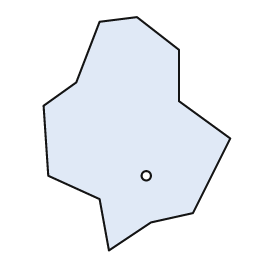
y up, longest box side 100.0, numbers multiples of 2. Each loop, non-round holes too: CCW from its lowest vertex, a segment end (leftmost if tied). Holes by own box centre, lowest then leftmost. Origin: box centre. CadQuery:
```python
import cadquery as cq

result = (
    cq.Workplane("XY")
    .moveTo(-12.0, -50.0)
    .lineTo(6.0, -38.0)
    .lineTo(24.0, -34.0)
    .lineTo(40.0, -2.0)
    .lineTo(18.0, 14.0)
    .lineTo(18.0, 36.0)
    .lineTo(0.0, 50.0)
    .lineTo(-16.0, 48.0)
    .lineTo(-26.0, 22.0)
    .lineTo(-40.0, 12.0)
    .lineTo(-38.0, -18.0)
    .lineTo(-16.0, -28.0)
    .close()
    .moveTo(4.0, -18.0)
    .circle(2.0)
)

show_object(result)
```